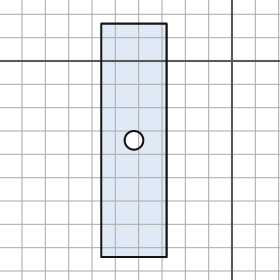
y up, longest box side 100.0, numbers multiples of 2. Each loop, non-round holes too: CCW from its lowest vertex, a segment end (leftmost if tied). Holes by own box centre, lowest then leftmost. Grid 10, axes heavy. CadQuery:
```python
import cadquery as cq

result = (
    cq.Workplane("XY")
    .moveTo(-56.0, -84.0)
    .lineTo(-28.0, -84.0)
    .lineTo(-28.0, 16.0)
    .lineTo(-56.0, 16.0)
    .close()
    .moveTo(-42.0, -34.0)
    .circle(4.0)
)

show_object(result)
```